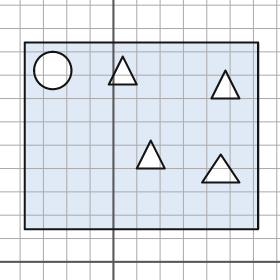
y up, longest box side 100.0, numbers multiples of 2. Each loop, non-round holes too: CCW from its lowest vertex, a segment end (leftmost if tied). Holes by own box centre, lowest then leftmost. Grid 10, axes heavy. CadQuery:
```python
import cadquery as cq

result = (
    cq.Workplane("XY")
    .moveTo(-38.0, 14.0)
    .lineTo(62.0, 14.0)
    .lineTo(62.0, 94.0)
    .lineTo(-38.0, 94.0)
    .close()
    .moveTo(38.0, 34.0)
    .lineTo(54.0, 34.0)
    .lineTo(46.0, 46.0)
    .close()
    .moveTo(10.0, 40.0)
    .lineTo(22.0, 40.0)
    .lineTo(16.0, 52.0)
    .close()
    .moveTo(42.0, 70.0)
    .lineTo(54.0, 70.0)
    .lineTo(48.0, 82.0)
    .close()
    .moveTo(-26.0, 82.0)
    .circle(8.0)
    .moveTo(-2.0, 76.0)
    .lineTo(10.0, 76.0)
    .lineTo(4.0, 88.0)
    .close()
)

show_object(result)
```